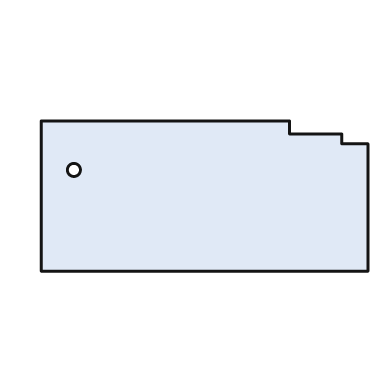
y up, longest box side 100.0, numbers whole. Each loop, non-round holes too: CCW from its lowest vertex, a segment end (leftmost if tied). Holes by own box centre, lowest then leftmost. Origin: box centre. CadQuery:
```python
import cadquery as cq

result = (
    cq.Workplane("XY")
    .moveTo(-50.0, -23.0)
    .lineTo(50.0, -23.0)
    .lineTo(50.0, 16.0)
    .lineTo(42.0, 16.0)
    .lineTo(42.0, 19.0)
    .lineTo(26.0, 19.0)
    .lineTo(26.0, 23.0)
    .lineTo(-50.0, 23.0)
    .close()
    .moveTo(-40.0, 8.0)
    .circle(2.0)
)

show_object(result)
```